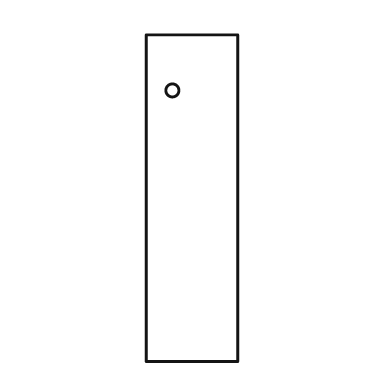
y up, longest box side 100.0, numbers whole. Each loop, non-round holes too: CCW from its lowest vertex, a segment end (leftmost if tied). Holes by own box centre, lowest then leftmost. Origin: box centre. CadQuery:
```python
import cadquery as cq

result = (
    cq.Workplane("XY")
    .moveTo(-14.0, -50.0)
    .lineTo(14.0, -50.0)
    .lineTo(14.0, 50.0)
    .lineTo(-14.0, 50.0)
    .close()
    .moveTo(-6.0, 33.0)
    .circle(2.0)
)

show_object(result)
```